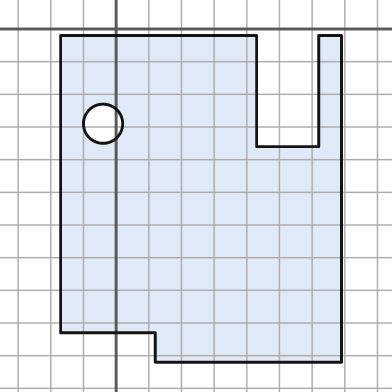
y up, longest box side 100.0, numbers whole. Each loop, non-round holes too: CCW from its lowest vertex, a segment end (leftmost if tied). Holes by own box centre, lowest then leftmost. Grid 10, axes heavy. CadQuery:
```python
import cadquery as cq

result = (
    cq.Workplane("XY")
    .moveTo(12.0, -102.0)
    .lineTo(69.0, -102.0)
    .lineTo(69.0, -2.0)
    .lineTo(62.0, -2.0)
    .lineTo(62.0, -36.0)
    .lineTo(43.0, -36.0)
    .lineTo(43.0, -2.0)
    .lineTo(-17.0, -2.0)
    .lineTo(-17.0, -93.0)
    .lineTo(12.0, -93.0)
    .close()
    .moveTo(-4.0, -29.0)
    .circle(6.0)
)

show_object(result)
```